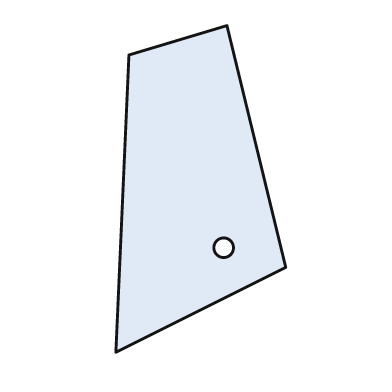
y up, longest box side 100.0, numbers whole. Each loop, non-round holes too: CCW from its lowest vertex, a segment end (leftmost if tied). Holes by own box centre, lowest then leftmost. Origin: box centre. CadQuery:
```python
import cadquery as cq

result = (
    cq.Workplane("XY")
    .moveTo(-26.0, -50.0)
    .lineTo(26.0, -24.0)
    .lineTo(8.0, 50.0)
    .lineTo(-22.0, 41.0)
    .close()
    .moveTo(7.0, -18.0)
    .circle(3.0)
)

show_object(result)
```